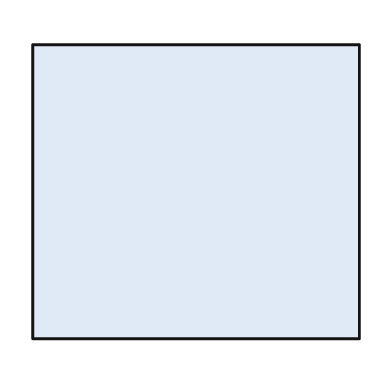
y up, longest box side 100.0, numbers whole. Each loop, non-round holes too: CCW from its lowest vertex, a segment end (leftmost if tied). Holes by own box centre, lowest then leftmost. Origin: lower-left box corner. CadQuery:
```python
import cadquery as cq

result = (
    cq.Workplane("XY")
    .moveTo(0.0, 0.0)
    .lineTo(100.0, 0.0)
    .lineTo(100.0, 90.0)
    .lineTo(0.0, 90.0)
    .close()
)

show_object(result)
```